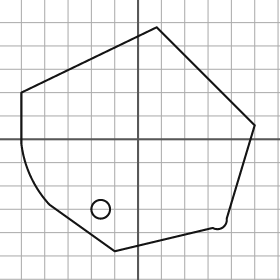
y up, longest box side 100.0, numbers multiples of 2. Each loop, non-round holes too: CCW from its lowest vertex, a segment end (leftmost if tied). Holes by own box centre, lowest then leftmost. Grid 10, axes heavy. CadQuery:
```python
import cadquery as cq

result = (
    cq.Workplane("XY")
    .moveTo(-10.0, -48.0)
    .lineTo(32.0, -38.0)
    .threePointArc((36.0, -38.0), (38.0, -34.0))
    .lineTo(50.0, 6.0)
    .lineTo(8.0, 48.0)
    .lineTo(-50.0, 20.0)
    .lineTo(-50.0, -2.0)
    .threePointArc((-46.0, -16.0), (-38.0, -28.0))
    .close()
    .moveTo(-16.0, -30.0)
    .circle(4.0)
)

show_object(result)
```